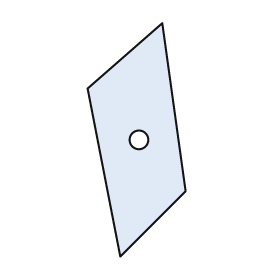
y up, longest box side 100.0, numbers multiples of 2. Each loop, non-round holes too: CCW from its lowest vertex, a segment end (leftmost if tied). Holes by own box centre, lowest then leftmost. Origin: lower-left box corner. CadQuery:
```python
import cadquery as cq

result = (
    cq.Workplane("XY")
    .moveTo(14.0, 0.0)
    .lineTo(42.0, 28.0)
    .lineTo(32.0, 100.0)
    .lineTo(0.0, 72.0)
    .close()
    .moveTo(22.0, 50.0)
    .circle(4.0)
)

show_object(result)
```